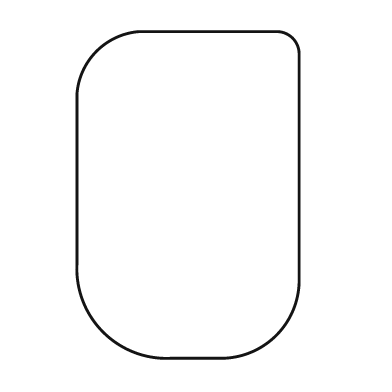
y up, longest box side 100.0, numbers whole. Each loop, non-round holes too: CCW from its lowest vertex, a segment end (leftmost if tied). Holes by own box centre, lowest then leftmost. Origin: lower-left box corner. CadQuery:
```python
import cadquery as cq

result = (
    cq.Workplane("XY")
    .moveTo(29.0, 0.0)
    .lineTo(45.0, 0.0)
    .threePointArc((61.0, 7.0), (68.0, 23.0))
    .lineTo(68.0, 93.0)
    .threePointArc((66.0, 98.0), (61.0, 100.0))
    .lineTo(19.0, 100.0)
    .threePointArc((6.0, 94.0), (0.0, 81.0))
    .lineTo(0.0, 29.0)
    .threePointArc((8.0, 8.0), (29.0, 0.0))
    .close()
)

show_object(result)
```